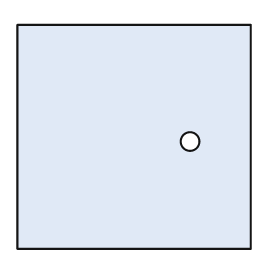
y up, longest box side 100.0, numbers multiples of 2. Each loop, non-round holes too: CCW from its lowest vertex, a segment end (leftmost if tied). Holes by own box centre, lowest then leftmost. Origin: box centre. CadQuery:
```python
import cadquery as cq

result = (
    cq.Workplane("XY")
    .moveTo(-50.0, -48.0)
    .lineTo(50.0, -48.0)
    .lineTo(50.0, 48.0)
    .lineTo(-50.0, 48.0)
    .close()
    .moveTo(24.0, -2.0)
    .circle(4.0)
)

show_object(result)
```